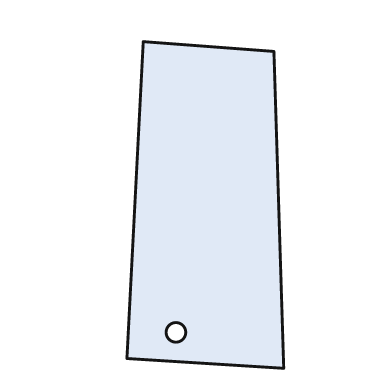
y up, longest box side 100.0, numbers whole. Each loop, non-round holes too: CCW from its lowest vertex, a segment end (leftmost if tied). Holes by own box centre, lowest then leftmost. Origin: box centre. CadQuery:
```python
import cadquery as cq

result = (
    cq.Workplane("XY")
    .moveTo(24.0, -50.0)
    .lineTo(21.0, 47.0)
    .lineTo(-19.0, 50.0)
    .lineTo(-24.0, -47.0)
    .close()
    .moveTo(-9.0, -39.0)
    .circle(3.0)
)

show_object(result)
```